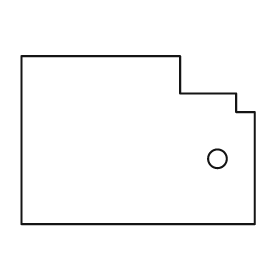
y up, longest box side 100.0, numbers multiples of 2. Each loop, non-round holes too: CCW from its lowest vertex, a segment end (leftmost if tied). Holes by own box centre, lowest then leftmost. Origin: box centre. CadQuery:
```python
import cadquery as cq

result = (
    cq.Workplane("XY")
    .moveTo(-50.0, -36.0)
    .lineTo(50.0, -36.0)
    .lineTo(50.0, 12.0)
    .lineTo(42.0, 12.0)
    .lineTo(42.0, 20.0)
    .lineTo(18.0, 20.0)
    .lineTo(18.0, 36.0)
    .lineTo(-50.0, 36.0)
    .close()
    .moveTo(34.0, -8.0)
    .circle(4.0)
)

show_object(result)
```